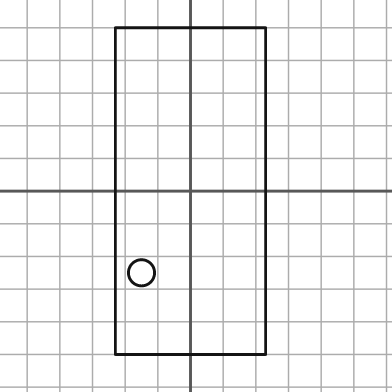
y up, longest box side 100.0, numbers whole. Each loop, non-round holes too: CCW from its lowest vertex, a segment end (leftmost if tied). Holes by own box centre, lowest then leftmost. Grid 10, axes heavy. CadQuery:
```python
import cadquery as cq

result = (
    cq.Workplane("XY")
    .moveTo(-23.0, -50.0)
    .lineTo(23.0, -50.0)
    .lineTo(23.0, 50.0)
    .lineTo(-23.0, 50.0)
    .close()
    .moveTo(-15.0, -25.0)
    .circle(4.0)
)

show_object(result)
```